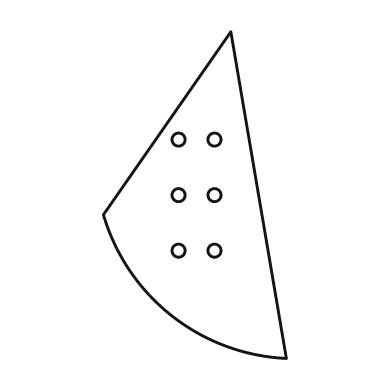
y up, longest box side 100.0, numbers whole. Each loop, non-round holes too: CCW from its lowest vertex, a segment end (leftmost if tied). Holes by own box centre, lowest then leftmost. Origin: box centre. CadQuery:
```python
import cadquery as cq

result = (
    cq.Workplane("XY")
    .moveTo(28.0, -50.0)
    .lineTo(11.0, 50.0)
    .lineTo(-28.0, -6.0)
    .threePointArc((-7.0, -37.0), (28.0, -50.0))
    .close()
    .moveTo(-5.0, -17.0)
    .circle(2.0)
    .moveTo(6.0, -17.0)
    .circle(2.0)
    .moveTo(-5.0, 0.0)
    .circle(2.0)
    .moveTo(6.0, 0.0)
    .circle(2.0)
    .moveTo(-5.0, 17.0)
    .circle(2.0)
    .moveTo(6.0, 17.0)
    .circle(2.0)
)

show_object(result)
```